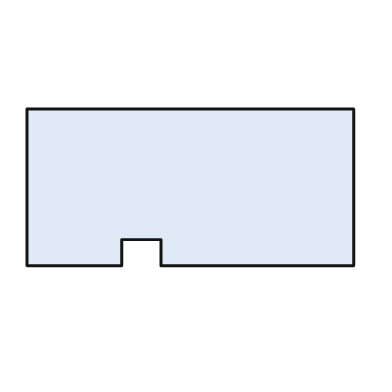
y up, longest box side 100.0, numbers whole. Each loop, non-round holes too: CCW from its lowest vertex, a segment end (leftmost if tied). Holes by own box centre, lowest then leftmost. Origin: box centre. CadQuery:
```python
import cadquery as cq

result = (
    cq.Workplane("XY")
    .moveTo(-50.0, -24.0)
    .lineTo(-21.0, -24.0)
    .lineTo(-21.0, -16.0)
    .lineTo(-9.0, -16.0)
    .lineTo(-9.0, -24.0)
    .lineTo(50.0, -24.0)
    .lineTo(50.0, 24.0)
    .lineTo(-50.0, 24.0)
    .close()
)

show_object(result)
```